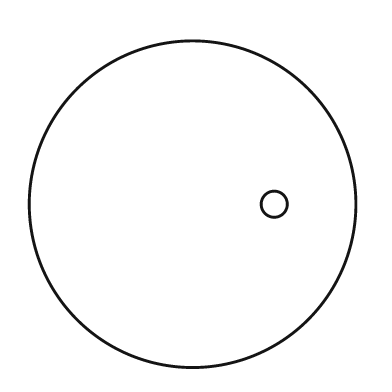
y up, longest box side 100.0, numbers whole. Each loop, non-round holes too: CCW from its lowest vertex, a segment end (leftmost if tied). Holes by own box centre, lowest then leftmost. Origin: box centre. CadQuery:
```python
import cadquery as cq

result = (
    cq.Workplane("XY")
    .moveTo(0.0, 0.0)
    .circle(50.0)
    .moveTo(25.0, 0.0)
    .circle(4.0)
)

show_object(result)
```